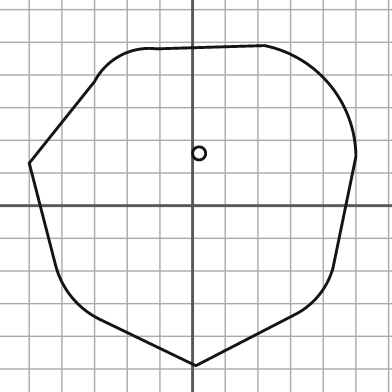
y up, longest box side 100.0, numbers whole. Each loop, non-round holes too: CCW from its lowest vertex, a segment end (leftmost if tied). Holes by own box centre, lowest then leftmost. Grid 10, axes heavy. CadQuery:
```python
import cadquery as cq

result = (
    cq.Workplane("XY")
    .moveTo(1.0, -49.0)
    .lineTo(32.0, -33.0)
    .threePointArc((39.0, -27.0), (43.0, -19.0))
    .lineTo(50.0, 15.0)
    .threePointArc((42.0, 37.0), (22.0, 49.0))
    .lineTo(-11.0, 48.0)
    .threePointArc((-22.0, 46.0), (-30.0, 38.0))
    .lineTo(-50.0, 13.0)
    .lineTo(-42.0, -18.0)
    .threePointArc((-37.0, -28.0), (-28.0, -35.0))
    .close()
    .moveTo(2.0, 16.0)
    .circle(2.0)
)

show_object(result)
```